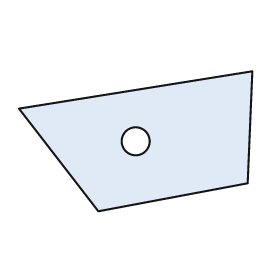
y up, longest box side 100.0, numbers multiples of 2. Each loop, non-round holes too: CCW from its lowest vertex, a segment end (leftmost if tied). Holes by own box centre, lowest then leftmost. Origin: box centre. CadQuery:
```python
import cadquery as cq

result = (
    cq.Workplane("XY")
    .moveTo(-16.0, -30.0)
    .lineTo(48.0, -18.0)
    .lineTo(50.0, 30.0)
    .lineTo(-50.0, 14.0)
    .close()
    .moveTo(0.0, 0.0)
    .circle(6.0)
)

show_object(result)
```